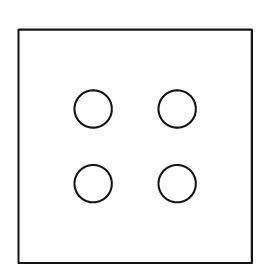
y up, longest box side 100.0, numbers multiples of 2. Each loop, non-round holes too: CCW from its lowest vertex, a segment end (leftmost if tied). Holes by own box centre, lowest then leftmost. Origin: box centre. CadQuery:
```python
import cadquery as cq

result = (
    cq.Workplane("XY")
    .moveTo(-50.0, -50.0)
    .lineTo(50.0, -50.0)
    .lineTo(50.0, 50.0)
    .lineTo(-50.0, 50.0)
    .close()
    .moveTo(-18.0, -16.0)
    .circle(8.0)
    .moveTo(18.0, -16.0)
    .circle(8.0)
    .moveTo(-18.0, 16.0)
    .circle(8.0)
    .moveTo(18.0, 16.0)
    .circle(8.0)
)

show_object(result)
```